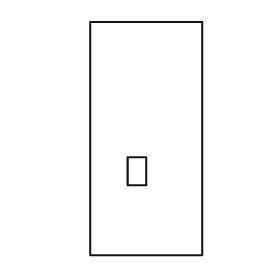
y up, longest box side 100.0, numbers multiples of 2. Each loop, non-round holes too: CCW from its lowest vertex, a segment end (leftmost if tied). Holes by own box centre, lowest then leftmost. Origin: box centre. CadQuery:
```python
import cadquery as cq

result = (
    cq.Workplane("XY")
    .moveTo(-24.0, -50.0)
    .lineTo(24.0, -50.0)
    .lineTo(24.0, 50.0)
    .lineTo(-24.0, 50.0)
    .close()
    .moveTo(-8.0, -20.0)
    .lineTo(0.0, -20.0)
    .lineTo(0.0, -8.0)
    .lineTo(-8.0, -8.0)
    .close()
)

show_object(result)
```